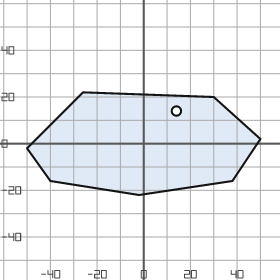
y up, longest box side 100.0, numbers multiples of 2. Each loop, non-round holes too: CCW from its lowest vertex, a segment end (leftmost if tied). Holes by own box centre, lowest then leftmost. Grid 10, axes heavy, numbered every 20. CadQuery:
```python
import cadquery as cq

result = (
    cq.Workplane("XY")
    .moveTo(-2.0, -22.0)
    .lineTo(38.0, -16.0)
    .lineTo(50.0, 2.0)
    .lineTo(30.0, 20.0)
    .lineTo(-26.0, 22.0)
    .lineTo(-50.0, -2.0)
    .lineTo(-40.0, -16.0)
    .close()
    .moveTo(14.0, 14.0)
    .circle(2.0)
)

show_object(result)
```